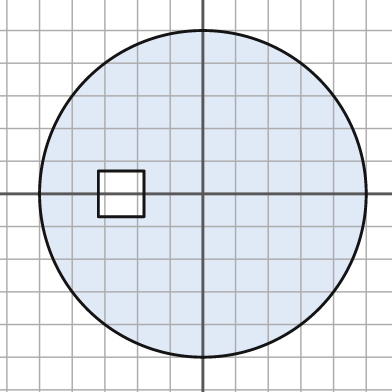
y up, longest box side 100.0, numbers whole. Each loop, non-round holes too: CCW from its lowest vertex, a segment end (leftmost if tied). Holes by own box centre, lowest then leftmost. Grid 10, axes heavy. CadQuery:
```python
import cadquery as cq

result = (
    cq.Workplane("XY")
    .moveTo(0.0, 0.0)
    .circle(50.0)
    .moveTo(-32.0, -7.0)
    .lineTo(-18.0, -7.0)
    .lineTo(-18.0, 7.0)
    .lineTo(-32.0, 7.0)
    .close()
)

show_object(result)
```